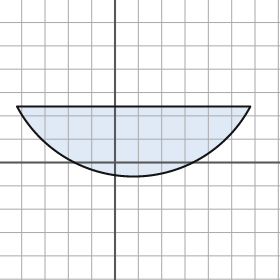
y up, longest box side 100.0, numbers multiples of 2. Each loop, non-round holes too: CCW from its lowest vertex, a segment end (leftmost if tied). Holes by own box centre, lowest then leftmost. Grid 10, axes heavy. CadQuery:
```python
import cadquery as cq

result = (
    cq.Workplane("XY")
    .moveTo(-42.0, 24.0)
    .threePointArc((8.0, -6.0), (58.0, 24.0))
    .close()
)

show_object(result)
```